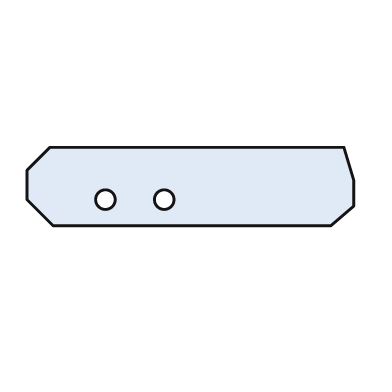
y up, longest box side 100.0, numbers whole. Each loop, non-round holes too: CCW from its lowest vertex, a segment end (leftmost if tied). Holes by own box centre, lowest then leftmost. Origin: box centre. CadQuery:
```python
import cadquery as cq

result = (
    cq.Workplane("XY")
    .moveTo(-42.0, -12.0)
    .lineTo(43.0, -12.0)
    .lineTo(50.0, -6.0)
    .lineTo(50.0, 2.0)
    .lineTo(47.0, 12.0)
    .lineTo(-43.0, 12.0)
    .lineTo(-50.0, 5.0)
    .lineTo(-50.0, -4.0)
    .close()
    .moveTo(-26.0, -4.0)
    .circle(3.0)
    .moveTo(-8.0, -4.0)
    .circle(3.0)
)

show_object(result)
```